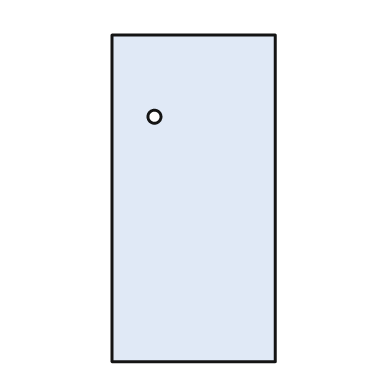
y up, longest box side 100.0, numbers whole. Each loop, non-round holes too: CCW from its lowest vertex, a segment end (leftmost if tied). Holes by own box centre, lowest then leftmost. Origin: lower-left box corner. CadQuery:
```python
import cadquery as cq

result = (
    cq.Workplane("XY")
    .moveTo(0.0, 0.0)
    .lineTo(50.0, 0.0)
    .lineTo(50.0, 100.0)
    .lineTo(0.0, 100.0)
    .close()
    .moveTo(13.0, 75.0)
    .circle(2.0)
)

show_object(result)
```